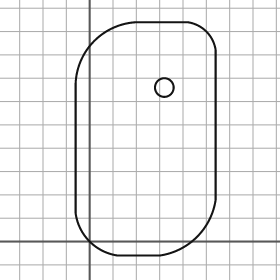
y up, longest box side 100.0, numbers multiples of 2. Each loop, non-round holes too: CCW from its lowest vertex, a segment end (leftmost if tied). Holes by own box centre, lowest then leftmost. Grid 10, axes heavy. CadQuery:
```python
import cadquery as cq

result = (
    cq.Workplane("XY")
    .moveTo(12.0, -6.0)
    .lineTo(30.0, -6.0)
    .threePointArc((46.0, 2.0), (54.0, 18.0))
    .lineTo(54.0, 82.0)
    .threePointArc((50.0, 90.0), (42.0, 94.0))
    .lineTo(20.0, 94.0)
    .threePointArc((2.0, 86.0), (-6.0, 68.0))
    .lineTo(-6.0, 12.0)
    .threePointArc((0.0, 0.0), (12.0, -6.0))
    .close()
    .moveTo(32.0, 66.0)
    .circle(4.0)
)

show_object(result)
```